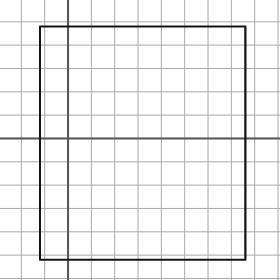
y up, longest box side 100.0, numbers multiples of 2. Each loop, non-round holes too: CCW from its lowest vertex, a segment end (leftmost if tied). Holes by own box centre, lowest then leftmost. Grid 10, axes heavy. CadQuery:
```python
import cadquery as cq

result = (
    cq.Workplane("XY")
    .moveTo(-12.0, -52.0)
    .lineTo(76.0, -52.0)
    .lineTo(76.0, 48.0)
    .lineTo(-12.0, 48.0)
    .close()
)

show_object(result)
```